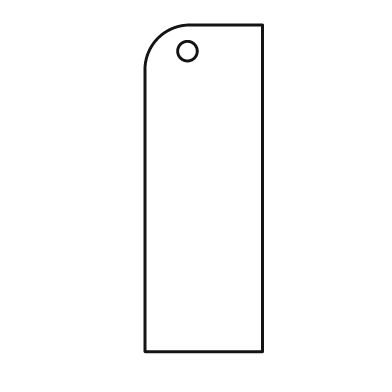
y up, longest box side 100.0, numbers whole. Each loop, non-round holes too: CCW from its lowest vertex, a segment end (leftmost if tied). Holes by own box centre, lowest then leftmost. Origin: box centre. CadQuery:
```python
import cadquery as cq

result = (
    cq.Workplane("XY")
    .moveTo(-18.0, -50.0)
    .lineTo(18.0, -50.0)
    .lineTo(18.0, 50.0)
    .lineTo(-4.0, 50.0)
    .threePointArc((-14.0, 46.0), (-18.0, 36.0))
    .close()
    .moveTo(-5.0, 42.0)
    .circle(3.0)
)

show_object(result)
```